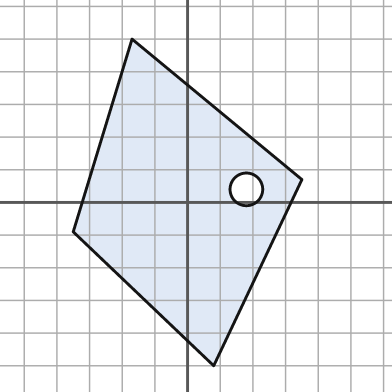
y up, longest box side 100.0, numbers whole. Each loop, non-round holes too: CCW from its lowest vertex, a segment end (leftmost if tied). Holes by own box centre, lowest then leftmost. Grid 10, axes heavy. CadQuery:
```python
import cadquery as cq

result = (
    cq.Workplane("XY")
    .moveTo(8.0, -50.0)
    .lineTo(35.0, 7.0)
    .lineTo(-17.0, 50.0)
    .lineTo(-35.0, -9.0)
    .close()
    .moveTo(18.0, 4.0)
    .circle(5.0)
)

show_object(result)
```